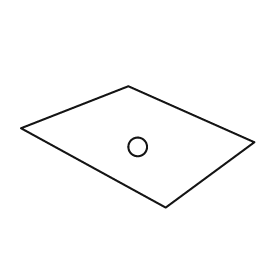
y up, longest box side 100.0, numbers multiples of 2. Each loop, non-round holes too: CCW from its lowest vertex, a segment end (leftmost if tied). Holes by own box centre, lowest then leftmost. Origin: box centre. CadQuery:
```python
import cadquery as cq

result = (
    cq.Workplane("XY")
    .moveTo(12.0, -26.0)
    .lineTo(50.0, 2.0)
    .lineTo(-4.0, 26.0)
    .lineTo(-50.0, 8.0)
    .close()
    .moveTo(0.0, 0.0)
    .circle(4.0)
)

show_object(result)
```